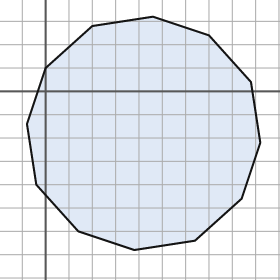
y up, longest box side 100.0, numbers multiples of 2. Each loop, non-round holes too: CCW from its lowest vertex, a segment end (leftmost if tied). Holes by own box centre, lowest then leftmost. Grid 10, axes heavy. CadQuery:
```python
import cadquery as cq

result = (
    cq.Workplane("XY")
    .moveTo(38.0, -68.0)
    .lineTo(64.0, -64.0)
    .lineTo(84.0, -46.0)
    .lineTo(92.0, -22.0)
    .lineTo(88.0, 4.0)
    .lineTo(70.0, 24.0)
    .lineTo(46.0, 32.0)
    .lineTo(20.0, 28.0)
    .lineTo(0.0, 10.0)
    .lineTo(-8.0, -14.0)
    .lineTo(-4.0, -40.0)
    .lineTo(14.0, -60.0)
    .close()
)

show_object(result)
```